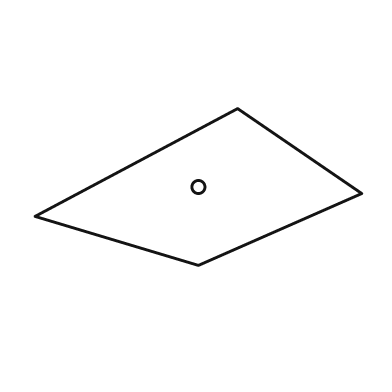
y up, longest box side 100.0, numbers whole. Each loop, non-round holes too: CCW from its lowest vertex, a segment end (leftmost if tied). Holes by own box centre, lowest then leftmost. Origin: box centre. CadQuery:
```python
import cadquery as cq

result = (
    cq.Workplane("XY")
    .moveTo(0.0, -24.0)
    .lineTo(50.0, -2.0)
    .lineTo(12.0, 24.0)
    .lineTo(-50.0, -9.0)
    .close()
    .moveTo(0.0, 0.0)
    .circle(2.0)
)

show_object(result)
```